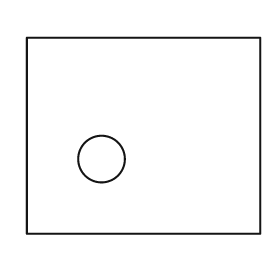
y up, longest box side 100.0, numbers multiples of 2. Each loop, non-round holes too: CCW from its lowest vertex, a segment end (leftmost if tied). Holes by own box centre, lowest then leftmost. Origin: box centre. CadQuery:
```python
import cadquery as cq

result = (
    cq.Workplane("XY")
    .moveTo(-50.0, -42.0)
    .lineTo(50.0, -42.0)
    .lineTo(50.0, 42.0)
    .lineTo(-50.0, 42.0)
    .close()
    .moveTo(-18.0, -10.0)
    .circle(10.0)
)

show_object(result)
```